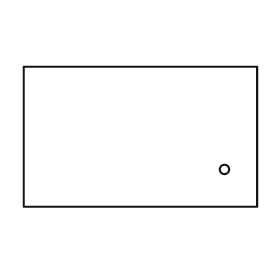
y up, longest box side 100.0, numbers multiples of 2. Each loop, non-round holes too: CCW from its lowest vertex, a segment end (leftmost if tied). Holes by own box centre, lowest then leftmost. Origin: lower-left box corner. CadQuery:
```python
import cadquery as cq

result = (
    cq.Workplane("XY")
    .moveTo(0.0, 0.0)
    .lineTo(100.0, 0.0)
    .lineTo(100.0, 60.0)
    .lineTo(0.0, 60.0)
    .close()
    .moveTo(86.0, 16.0)
    .circle(2.0)
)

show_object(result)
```